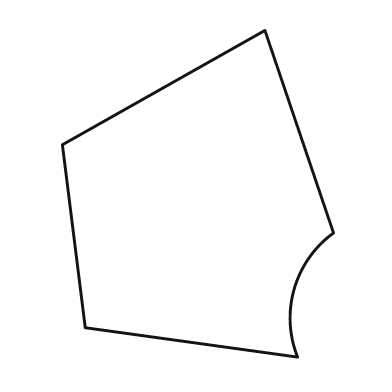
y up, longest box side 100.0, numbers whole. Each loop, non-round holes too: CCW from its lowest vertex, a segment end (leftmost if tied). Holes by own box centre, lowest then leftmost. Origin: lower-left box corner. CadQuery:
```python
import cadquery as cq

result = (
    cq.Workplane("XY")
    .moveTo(72.0, 0.0)
    .threePointArc((71.0, 21.0), (83.0, 38.0))
    .lineTo(62.0, 100.0)
    .lineTo(0.0, 65.0)
    .lineTo(7.0, 9.0)
    .close()
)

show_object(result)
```